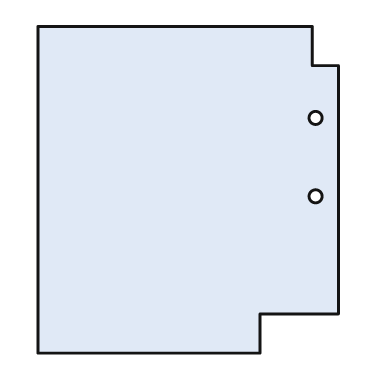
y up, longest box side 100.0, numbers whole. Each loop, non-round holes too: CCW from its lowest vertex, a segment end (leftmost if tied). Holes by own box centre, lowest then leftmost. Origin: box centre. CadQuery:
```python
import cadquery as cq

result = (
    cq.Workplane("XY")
    .moveTo(-46.0, -50.0)
    .lineTo(22.0, -50.0)
    .lineTo(22.0, -38.0)
    .lineTo(46.0, -38.0)
    .lineTo(46.0, 38.0)
    .lineTo(38.0, 38.0)
    .lineTo(38.0, 50.0)
    .lineTo(-46.0, 50.0)
    .close()
    .moveTo(39.0, -2.0)
    .circle(2.0)
    .moveTo(39.0, 22.0)
    .circle(2.0)
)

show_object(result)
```